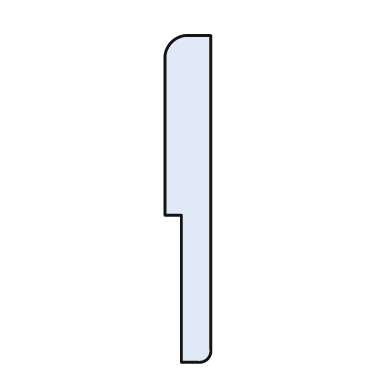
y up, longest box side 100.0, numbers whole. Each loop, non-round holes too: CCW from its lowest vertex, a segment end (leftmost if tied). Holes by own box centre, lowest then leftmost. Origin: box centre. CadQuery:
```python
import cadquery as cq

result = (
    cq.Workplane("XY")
    .moveTo(-2.0, -50.0)
    .lineTo(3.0, -50.0)
    .threePointArc((6.0, -49.0), (7.0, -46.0))
    .lineTo(7.0, 50.0)
    .lineTo(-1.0, 50.0)
    .threePointArc((-5.0, 48.0), (-7.0, 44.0))
    .lineTo(-7.0, -5.0)
    .lineTo(-2.0, -5.0)
    .close()
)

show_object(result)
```